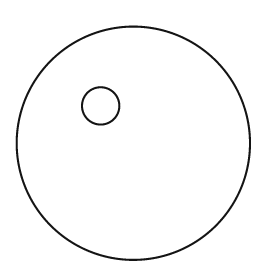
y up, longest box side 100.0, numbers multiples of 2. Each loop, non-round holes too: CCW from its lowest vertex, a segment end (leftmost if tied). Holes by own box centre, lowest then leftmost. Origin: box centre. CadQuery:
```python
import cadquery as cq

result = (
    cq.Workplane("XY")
    .moveTo(0.0, 0.0)
    .circle(50.0)
    .moveTo(-14.0, 16.0)
    .circle(8.0)
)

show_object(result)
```